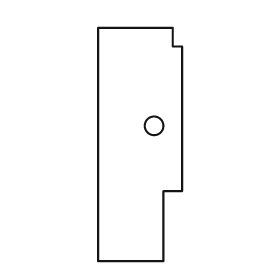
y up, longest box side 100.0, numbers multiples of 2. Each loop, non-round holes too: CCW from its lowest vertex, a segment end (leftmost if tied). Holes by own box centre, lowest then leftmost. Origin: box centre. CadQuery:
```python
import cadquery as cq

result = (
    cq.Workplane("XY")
    .moveTo(-18.0, -50.0)
    .lineTo(10.0, -50.0)
    .lineTo(10.0, -20.0)
    .lineTo(18.0, -20.0)
    .lineTo(18.0, 42.0)
    .lineTo(14.0, 42.0)
    .lineTo(14.0, 50.0)
    .lineTo(-18.0, 50.0)
    .close()
    .moveTo(6.0, 8.0)
    .circle(4.0)
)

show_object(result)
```